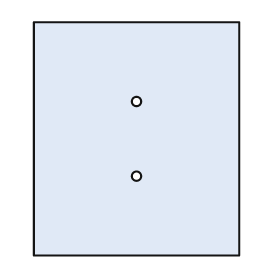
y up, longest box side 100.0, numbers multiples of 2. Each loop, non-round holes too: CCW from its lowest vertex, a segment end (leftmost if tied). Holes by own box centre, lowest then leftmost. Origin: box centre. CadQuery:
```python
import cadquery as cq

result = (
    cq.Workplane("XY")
    .moveTo(-44.0, -50.0)
    .lineTo(44.0, -50.0)
    .lineTo(44.0, 50.0)
    .lineTo(-44.0, 50.0)
    .close()
    .moveTo(0.0, -16.0)
    .circle(2.0)
    .moveTo(0.0, 16.0)
    .circle(2.0)
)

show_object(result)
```